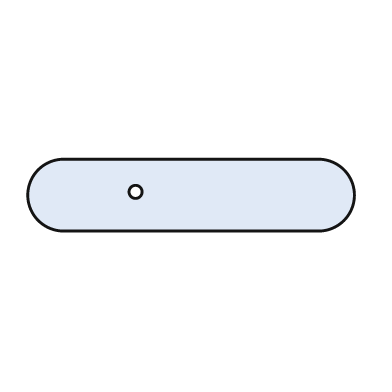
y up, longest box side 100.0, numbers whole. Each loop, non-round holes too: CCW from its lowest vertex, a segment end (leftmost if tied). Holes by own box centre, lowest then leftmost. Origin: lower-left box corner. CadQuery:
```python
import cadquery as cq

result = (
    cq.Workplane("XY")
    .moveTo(11.0, 0.0)
    .lineTo(89.0, 0.0)
    .threePointArc((100.0, 11.0), (89.0, 22.0))
    .lineTo(11.0, 22.0)
    .threePointArc((0.0, 11.0), (11.0, 0.0))
    .close()
    .moveTo(33.0, 12.0)
    .circle(2.0)
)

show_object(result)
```